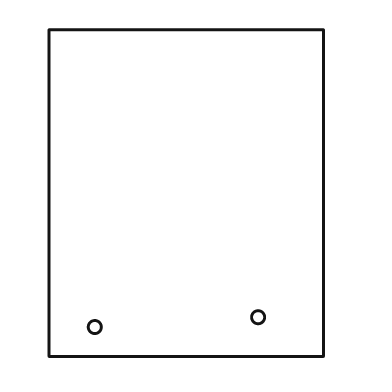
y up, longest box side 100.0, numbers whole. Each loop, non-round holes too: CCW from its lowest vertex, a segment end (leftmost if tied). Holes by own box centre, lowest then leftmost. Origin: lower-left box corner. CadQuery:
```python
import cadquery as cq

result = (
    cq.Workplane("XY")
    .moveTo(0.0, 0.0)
    .lineTo(84.0, 0.0)
    .lineTo(84.0, 100.0)
    .lineTo(0.0, 100.0)
    .close()
    .moveTo(14.0, 9.0)
    .circle(2.0)
    .moveTo(64.0, 12.0)
    .circle(2.0)
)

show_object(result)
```